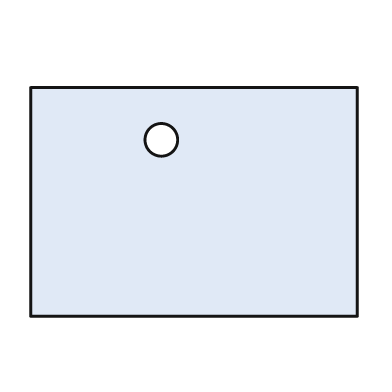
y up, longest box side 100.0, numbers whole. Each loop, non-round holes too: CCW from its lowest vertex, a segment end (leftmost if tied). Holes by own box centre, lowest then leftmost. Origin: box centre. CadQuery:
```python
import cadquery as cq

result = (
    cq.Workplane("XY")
    .moveTo(-50.0, -35.0)
    .lineTo(50.0, -35.0)
    .lineTo(50.0, 35.0)
    .lineTo(-50.0, 35.0)
    .close()
    .moveTo(-10.0, 19.0)
    .circle(5.0)
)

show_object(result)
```